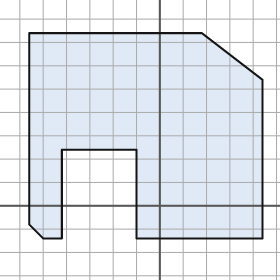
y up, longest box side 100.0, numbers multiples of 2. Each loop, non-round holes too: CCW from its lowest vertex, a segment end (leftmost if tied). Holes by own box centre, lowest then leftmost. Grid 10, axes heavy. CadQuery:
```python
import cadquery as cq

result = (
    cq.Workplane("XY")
    .moveTo(-50.0, -14.0)
    .lineTo(-42.0, -14.0)
    .lineTo(-42.0, 24.0)
    .lineTo(-10.0, 24.0)
    .lineTo(-10.0, -14.0)
    .lineTo(44.0, -14.0)
    .lineTo(44.0, 54.0)
    .lineTo(18.0, 74.0)
    .lineTo(-56.0, 74.0)
    .lineTo(-56.0, -8.0)
    .close()
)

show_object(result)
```